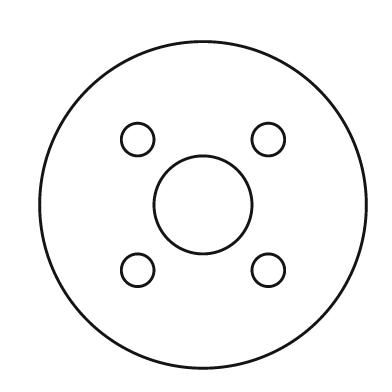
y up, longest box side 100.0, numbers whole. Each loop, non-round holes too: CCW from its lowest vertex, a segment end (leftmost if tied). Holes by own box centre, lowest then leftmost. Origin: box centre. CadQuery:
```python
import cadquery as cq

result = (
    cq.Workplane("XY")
    .moveTo(0.0, 0.0)
    .circle(50.0)
    .moveTo(-20.0, -20.0)
    .circle(5.0)
    .moveTo(20.0, -20.0)
    .circle(5.0)
    .moveTo(0.0, 0.0)
    .circle(15.0)
    .moveTo(-20.0, 20.0)
    .circle(5.0)
    .moveTo(20.0, 20.0)
    .circle(5.0)
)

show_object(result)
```